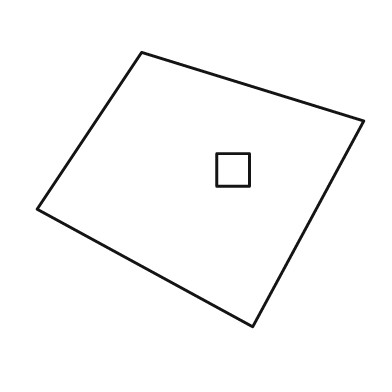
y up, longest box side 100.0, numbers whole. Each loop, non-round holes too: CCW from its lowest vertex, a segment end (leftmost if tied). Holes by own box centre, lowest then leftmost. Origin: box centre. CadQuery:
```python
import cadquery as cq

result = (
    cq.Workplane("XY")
    .moveTo(16.0, -42.0)
    .lineTo(50.0, 21.0)
    .lineTo(-18.0, 42.0)
    .lineTo(-50.0, -6.0)
    .close()
    .moveTo(5.0, 1.0)
    .lineTo(15.0, 1.0)
    .lineTo(15.0, 11.0)
    .lineTo(5.0, 11.0)
    .close()
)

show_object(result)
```